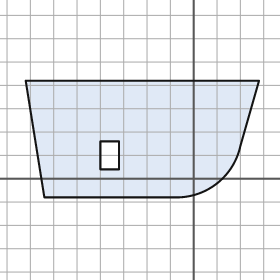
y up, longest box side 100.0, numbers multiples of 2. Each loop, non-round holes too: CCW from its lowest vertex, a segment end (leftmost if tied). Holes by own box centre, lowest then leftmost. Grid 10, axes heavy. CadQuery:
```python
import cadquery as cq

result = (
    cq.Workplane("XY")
    .moveTo(-64.0, -8.0)
    .lineTo(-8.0, -8.0)
    .threePointArc((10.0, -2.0), (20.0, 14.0))
    .lineTo(28.0, 42.0)
    .lineTo(-72.0, 42.0)
    .close()
    .moveTo(-40.0, 4.0)
    .lineTo(-32.0, 4.0)
    .lineTo(-32.0, 16.0)
    .lineTo(-40.0, 16.0)
    .close()
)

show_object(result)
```